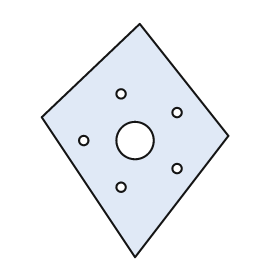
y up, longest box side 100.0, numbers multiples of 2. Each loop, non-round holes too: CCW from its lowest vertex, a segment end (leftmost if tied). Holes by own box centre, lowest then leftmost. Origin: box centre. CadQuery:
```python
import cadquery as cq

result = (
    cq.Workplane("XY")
    .moveTo(0.0, -50.0)
    .lineTo(40.0, 2.0)
    .lineTo(2.0, 50.0)
    .lineTo(-40.0, 10.0)
    .close()
    .moveTo(-6.0, -20.0)
    .circle(2.0)
    .moveTo(18.0, -12.0)
    .circle(2.0)
    .moveTo(-22.0, 0.0)
    .circle(2.0)
    .moveTo(0.0, 0.0)
    .circle(8.0)
    .moveTo(18.0, 12.0)
    .circle(2.0)
    .moveTo(-6.0, 20.0)
    .circle(2.0)
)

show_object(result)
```